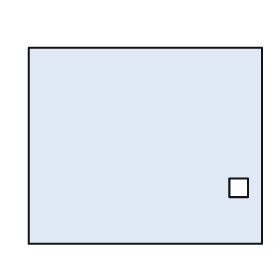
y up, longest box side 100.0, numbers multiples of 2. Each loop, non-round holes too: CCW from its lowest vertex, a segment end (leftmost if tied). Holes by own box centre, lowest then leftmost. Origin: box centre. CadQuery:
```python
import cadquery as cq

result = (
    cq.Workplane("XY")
    .moveTo(-50.0, -42.0)
    .lineTo(50.0, -42.0)
    .lineTo(50.0, 42.0)
    .lineTo(-50.0, 42.0)
    .close()
    .moveTo(36.0, -22.0)
    .lineTo(44.0, -22.0)
    .lineTo(44.0, -14.0)
    .lineTo(36.0, -14.0)
    .close()
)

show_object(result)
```